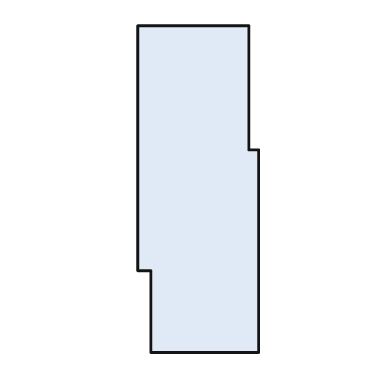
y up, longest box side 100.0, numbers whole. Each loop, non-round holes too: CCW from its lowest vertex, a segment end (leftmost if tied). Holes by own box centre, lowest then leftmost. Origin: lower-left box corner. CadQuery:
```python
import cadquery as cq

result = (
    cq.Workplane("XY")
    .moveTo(4.0, 0.0)
    .lineTo(37.0, 0.0)
    .lineTo(37.0, 62.0)
    .lineTo(34.0, 62.0)
    .lineTo(34.0, 100.0)
    .lineTo(0.0, 100.0)
    .lineTo(0.0, 25.0)
    .lineTo(4.0, 25.0)
    .close()
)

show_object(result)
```